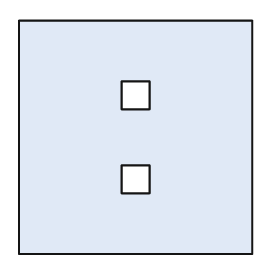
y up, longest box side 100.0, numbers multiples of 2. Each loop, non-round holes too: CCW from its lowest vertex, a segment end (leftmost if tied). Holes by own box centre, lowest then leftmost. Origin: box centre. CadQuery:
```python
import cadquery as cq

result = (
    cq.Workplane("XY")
    .moveTo(-50.0, -50.0)
    .lineTo(50.0, -50.0)
    .lineTo(50.0, 50.0)
    .lineTo(-50.0, 50.0)
    .close()
    .moveTo(-6.0, -24.0)
    .lineTo(6.0, -24.0)
    .lineTo(6.0, -12.0)
    .lineTo(-6.0, -12.0)
    .close()
    .moveTo(-6.0, 12.0)
    .lineTo(6.0, 12.0)
    .lineTo(6.0, 24.0)
    .lineTo(-6.0, 24.0)
    .close()
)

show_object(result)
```